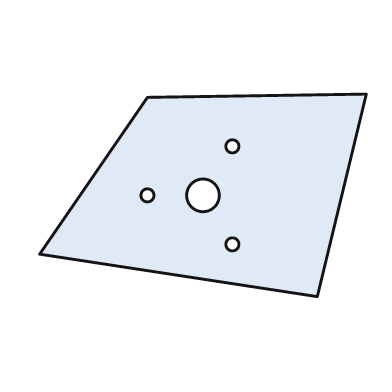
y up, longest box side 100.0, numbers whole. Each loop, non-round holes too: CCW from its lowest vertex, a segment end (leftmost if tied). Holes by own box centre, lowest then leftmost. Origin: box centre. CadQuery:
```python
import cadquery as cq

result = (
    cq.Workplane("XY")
    .moveTo(35.0, -31.0)
    .lineTo(50.0, 31.0)
    .lineTo(-17.0, 30.0)
    .lineTo(-50.0, -18.0)
    .close()
    .moveTo(9.0, -15.0)
    .circle(2.0)
    .moveTo(-17.0, 0.0)
    .circle(2.0)
    .moveTo(0.0, 0.0)
    .circle(5.0)
    .moveTo(9.0, 15.0)
    .circle(2.0)
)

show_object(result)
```